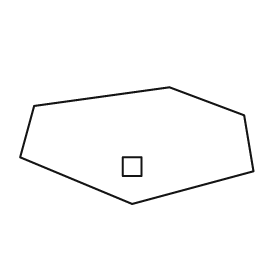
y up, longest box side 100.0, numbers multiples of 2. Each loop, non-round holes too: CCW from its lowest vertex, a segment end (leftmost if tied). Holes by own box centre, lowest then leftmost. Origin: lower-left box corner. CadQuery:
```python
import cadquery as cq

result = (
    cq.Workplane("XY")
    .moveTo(48.0, 0.0)
    .lineTo(100.0, 14.0)
    .lineTo(96.0, 38.0)
    .lineTo(64.0, 50.0)
    .lineTo(6.0, 42.0)
    .lineTo(0.0, 20.0)
    .close()
    .moveTo(44.0, 12.0)
    .lineTo(52.0, 12.0)
    .lineTo(52.0, 20.0)
    .lineTo(44.0, 20.0)
    .close()
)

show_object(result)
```